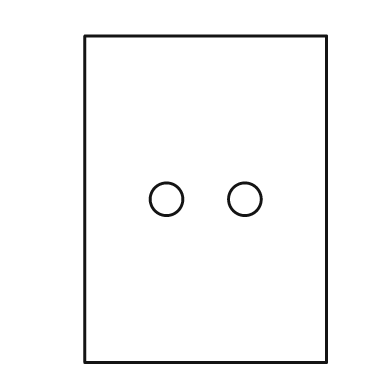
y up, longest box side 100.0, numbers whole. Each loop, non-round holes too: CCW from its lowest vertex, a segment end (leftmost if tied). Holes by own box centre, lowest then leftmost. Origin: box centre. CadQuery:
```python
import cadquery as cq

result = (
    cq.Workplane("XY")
    .moveTo(-37.0, -50.0)
    .lineTo(37.0, -50.0)
    .lineTo(37.0, 50.0)
    .lineTo(-37.0, 50.0)
    .close()
    .moveTo(-12.0, 0.0)
    .circle(5.0)
    .moveTo(12.0, 0.0)
    .circle(5.0)
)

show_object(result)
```